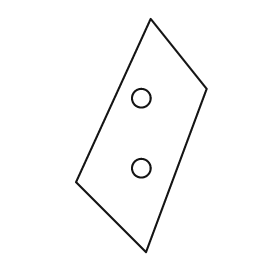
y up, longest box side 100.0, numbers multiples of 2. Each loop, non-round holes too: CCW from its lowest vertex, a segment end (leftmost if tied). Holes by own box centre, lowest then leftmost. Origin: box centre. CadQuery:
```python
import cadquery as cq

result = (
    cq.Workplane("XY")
    .moveTo(2.0, -50.0)
    .lineTo(28.0, 20.0)
    .lineTo(4.0, 50.0)
    .lineTo(-28.0, -20.0)
    .close()
    .moveTo(0.0, -14.0)
    .circle(4.0)
    .moveTo(0.0, 16.0)
    .circle(4.0)
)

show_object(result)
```